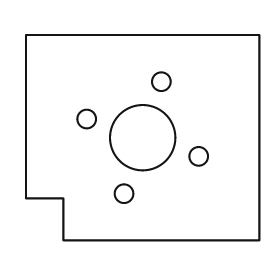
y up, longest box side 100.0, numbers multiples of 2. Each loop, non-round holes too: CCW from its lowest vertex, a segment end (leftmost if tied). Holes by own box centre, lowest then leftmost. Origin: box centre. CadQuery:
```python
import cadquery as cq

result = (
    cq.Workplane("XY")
    .moveTo(-34.0, -44.0)
    .lineTo(50.0, -44.0)
    .lineTo(50.0, 44.0)
    .lineTo(-50.0, 44.0)
    .lineTo(-50.0, -26.0)
    .lineTo(-34.0, -26.0)
    .close()
    .moveTo(-8.0, -24.0)
    .circle(4.0)
    .moveTo(24.0, -8.0)
    .circle(4.0)
    .moveTo(0.0, 0.0)
    .circle(14.0)
    .moveTo(-24.0, 8.0)
    .circle(4.0)
    .moveTo(8.0, 24.0)
    .circle(4.0)
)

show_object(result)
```